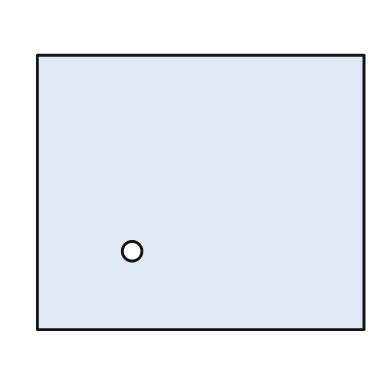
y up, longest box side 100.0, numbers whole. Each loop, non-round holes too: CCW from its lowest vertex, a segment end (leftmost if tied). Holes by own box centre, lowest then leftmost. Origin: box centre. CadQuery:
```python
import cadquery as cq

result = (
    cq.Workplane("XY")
    .moveTo(-50.0, -42.0)
    .lineTo(50.0, -42.0)
    .lineTo(50.0, 42.0)
    .lineTo(-50.0, 42.0)
    .close()
    .moveTo(-21.0, -18.0)
    .circle(3.0)
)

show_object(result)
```